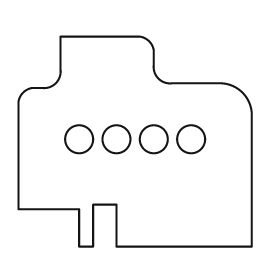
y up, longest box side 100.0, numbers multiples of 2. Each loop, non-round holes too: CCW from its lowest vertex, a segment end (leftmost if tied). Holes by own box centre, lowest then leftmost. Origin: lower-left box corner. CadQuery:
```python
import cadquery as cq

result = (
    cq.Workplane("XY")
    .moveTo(26.0, 0.0)
    .lineTo(32.0, 0.0)
    .lineTo(32.0, 18.0)
    .lineTo(42.0, 18.0)
    .lineTo(42.0, 0.0)
    .lineTo(100.0, 0.0)
    .lineTo(100.0, 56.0)
    .threePointArc((96.0, 66.0), (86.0, 70.0))
    .lineTo(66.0, 70.0)
    .threePointArc((60.0, 72.0), (58.0, 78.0))
    .lineTo(58.0, 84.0)
    .threePointArc((56.0, 88.0), (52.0, 90.0))
    .lineTo(18.0, 90.0)
    .lineTo(18.0, 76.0)
    .threePointArc((16.0, 70.0), (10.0, 68.0))
    .lineTo(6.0, 68.0)
    .threePointArc((2.0, 66.0), (0.0, 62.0))
    .lineTo(0.0, 16.0)
    .lineTo(26.0, 16.0)
    .close()
    .moveTo(26.0, 46.0)
    .circle(6.0)
    .moveTo(42.0, 46.0)
    .circle(6.0)
    .moveTo(58.0, 46.0)
    .circle(6.0)
    .moveTo(74.0, 46.0)
    .circle(6.0)
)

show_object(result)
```